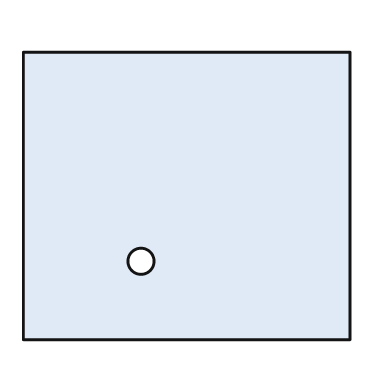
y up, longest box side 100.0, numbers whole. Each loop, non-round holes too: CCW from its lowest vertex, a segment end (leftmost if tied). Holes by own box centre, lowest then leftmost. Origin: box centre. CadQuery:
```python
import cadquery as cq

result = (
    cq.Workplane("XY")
    .moveTo(-50.0, -44.0)
    .lineTo(50.0, -44.0)
    .lineTo(50.0, 44.0)
    .lineTo(-50.0, 44.0)
    .close()
    .moveTo(-14.0, -20.0)
    .circle(4.0)
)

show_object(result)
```